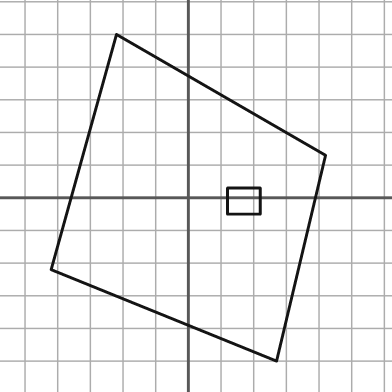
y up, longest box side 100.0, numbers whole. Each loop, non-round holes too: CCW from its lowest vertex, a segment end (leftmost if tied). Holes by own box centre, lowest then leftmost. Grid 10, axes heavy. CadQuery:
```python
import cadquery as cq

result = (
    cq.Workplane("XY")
    .moveTo(27.0, -50.0)
    .lineTo(42.0, 13.0)
    .lineTo(-22.0, 50.0)
    .lineTo(-42.0, -22.0)
    .close()
    .moveTo(12.0, -5.0)
    .lineTo(22.0, -5.0)
    .lineTo(22.0, 3.0)
    .lineTo(12.0, 3.0)
    .close()
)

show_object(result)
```